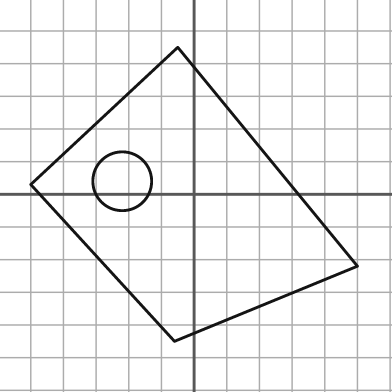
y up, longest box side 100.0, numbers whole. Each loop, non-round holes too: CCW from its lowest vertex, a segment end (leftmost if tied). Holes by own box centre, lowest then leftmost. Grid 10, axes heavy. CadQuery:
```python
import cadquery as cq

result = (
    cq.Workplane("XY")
    .moveTo(-6.0, -45.0)
    .lineTo(50.0, -22.0)
    .lineTo(-5.0, 45.0)
    .lineTo(-50.0, 3.0)
    .close()
    .moveTo(-22.0, 4.0)
    .circle(9.0)
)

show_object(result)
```